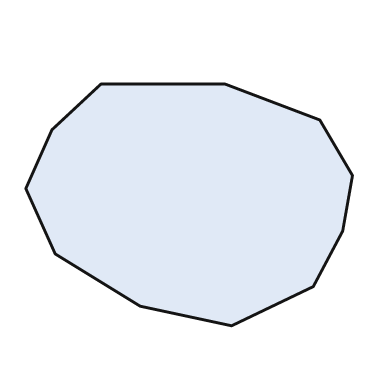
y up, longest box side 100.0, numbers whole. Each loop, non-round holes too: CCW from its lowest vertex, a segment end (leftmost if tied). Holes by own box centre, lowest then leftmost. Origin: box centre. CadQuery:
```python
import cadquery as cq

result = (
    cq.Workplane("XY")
    .moveTo(13.0, -37.0)
    .lineTo(38.0, -25.0)
    .lineTo(47.0, -8.0)
    .lineTo(50.0, 9.0)
    .lineTo(40.0, 26.0)
    .lineTo(11.0, 37.0)
    .lineTo(-27.0, 37.0)
    .lineTo(-42.0, 23.0)
    .lineTo(-50.0, 5.0)
    .lineTo(-41.0, -15.0)
    .lineTo(-15.0, -31.0)
    .close()
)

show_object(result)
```